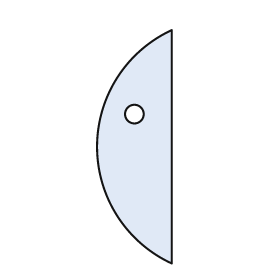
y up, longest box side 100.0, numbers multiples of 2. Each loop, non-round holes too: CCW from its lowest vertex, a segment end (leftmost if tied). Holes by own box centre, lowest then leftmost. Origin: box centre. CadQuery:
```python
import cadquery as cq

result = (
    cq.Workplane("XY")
    .moveTo(16.0, -50.0)
    .lineTo(16.0, 50.0)
    .threePointArc((-16.0, 0.0), (16.0, -50.0))
    .close()
    .moveTo(0.0, 14.0)
    .circle(4.0)
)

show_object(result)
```